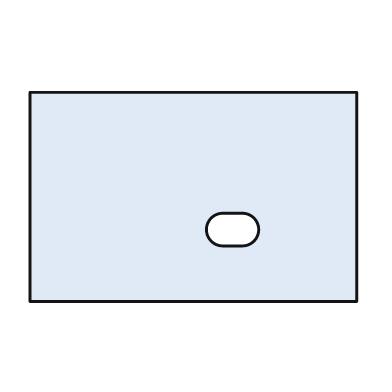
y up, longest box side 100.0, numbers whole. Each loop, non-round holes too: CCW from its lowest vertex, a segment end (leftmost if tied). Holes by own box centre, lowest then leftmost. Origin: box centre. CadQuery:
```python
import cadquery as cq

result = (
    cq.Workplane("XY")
    .moveTo(-50.0, -32.0)
    .lineTo(50.0, -32.0)
    .lineTo(50.0, 32.0)
    .lineTo(-50.0, 32.0)
    .close()
    .moveTo(9.0, -15.0)
    .lineTo(15.0, -15.0)
    .threePointArc((20.0, -10.0), (15.0, -5.0))
    .lineTo(9.0, -5.0)
    .threePointArc((4.0, -10.0), (9.0, -15.0))
    .close()
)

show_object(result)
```